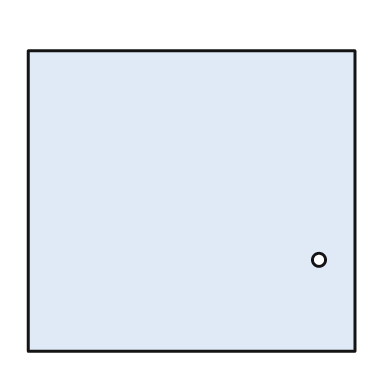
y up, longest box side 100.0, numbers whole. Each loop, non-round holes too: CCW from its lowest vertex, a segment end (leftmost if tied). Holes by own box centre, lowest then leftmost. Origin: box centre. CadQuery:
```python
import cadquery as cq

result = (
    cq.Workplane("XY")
    .moveTo(-50.0, -46.0)
    .lineTo(50.0, -46.0)
    .lineTo(50.0, 46.0)
    .lineTo(-50.0, 46.0)
    .close()
    .moveTo(39.0, -18.0)
    .circle(2.0)
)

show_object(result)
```